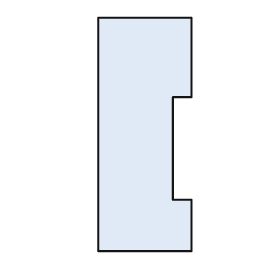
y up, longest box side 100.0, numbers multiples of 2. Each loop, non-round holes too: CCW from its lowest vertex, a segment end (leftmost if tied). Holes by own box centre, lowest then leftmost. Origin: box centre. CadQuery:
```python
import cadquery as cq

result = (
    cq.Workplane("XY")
    .moveTo(-20.0, -50.0)
    .lineTo(20.0, -50.0)
    .lineTo(20.0, -28.0)
    .lineTo(12.0, -28.0)
    .lineTo(12.0, 16.0)
    .lineTo(20.0, 16.0)
    .lineTo(20.0, 50.0)
    .lineTo(-20.0, 50.0)
    .close()
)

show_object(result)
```